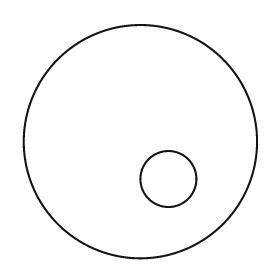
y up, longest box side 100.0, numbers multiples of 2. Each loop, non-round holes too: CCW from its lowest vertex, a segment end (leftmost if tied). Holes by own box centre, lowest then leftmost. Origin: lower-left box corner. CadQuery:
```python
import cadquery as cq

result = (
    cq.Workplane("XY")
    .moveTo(50.0, 50.0)
    .circle(50.0)
    .moveTo(62.0, 34.0)
    .circle(12.0)
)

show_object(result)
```